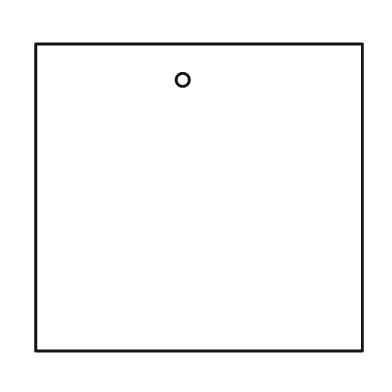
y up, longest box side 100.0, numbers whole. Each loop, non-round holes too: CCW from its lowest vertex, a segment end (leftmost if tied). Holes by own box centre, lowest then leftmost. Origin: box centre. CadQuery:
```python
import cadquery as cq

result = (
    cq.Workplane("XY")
    .moveTo(-50.0, -47.0)
    .lineTo(50.0, -47.0)
    .lineTo(50.0, 47.0)
    .lineTo(-50.0, 47.0)
    .close()
    .moveTo(-5.0, 36.0)
    .circle(2.0)
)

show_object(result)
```